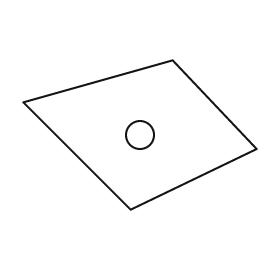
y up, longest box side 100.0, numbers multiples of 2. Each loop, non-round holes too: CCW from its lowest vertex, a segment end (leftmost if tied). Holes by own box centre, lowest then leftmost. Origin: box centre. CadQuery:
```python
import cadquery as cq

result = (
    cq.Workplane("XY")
    .moveTo(-4.0, -32.0)
    .lineTo(50.0, -6.0)
    .lineTo(14.0, 32.0)
    .lineTo(-50.0, 14.0)
    .close()
    .moveTo(0.0, 0.0)
    .circle(6.0)
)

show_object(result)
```